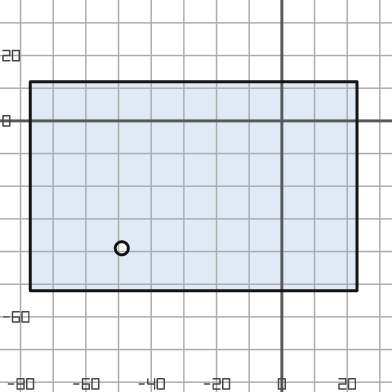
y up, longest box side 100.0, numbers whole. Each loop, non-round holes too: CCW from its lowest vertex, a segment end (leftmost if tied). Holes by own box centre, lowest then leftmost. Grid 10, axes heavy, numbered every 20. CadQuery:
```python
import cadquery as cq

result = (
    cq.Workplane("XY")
    .moveTo(-77.0, -52.0)
    .lineTo(23.0, -52.0)
    .lineTo(23.0, 12.0)
    .lineTo(-77.0, 12.0)
    .close()
    .moveTo(-49.0, -39.0)
    .circle(2.0)
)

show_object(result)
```